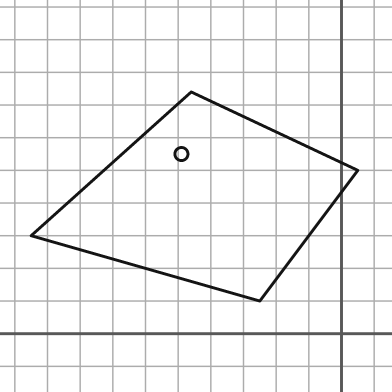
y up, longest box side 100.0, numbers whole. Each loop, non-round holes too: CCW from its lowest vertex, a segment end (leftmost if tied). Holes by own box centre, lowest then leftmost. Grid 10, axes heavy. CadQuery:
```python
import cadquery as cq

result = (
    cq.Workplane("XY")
    .moveTo(-25.0, 10.0)
    .lineTo(5.0, 50.0)
    .lineTo(-46.0, 74.0)
    .lineTo(-95.0, 30.0)
    .close()
    .moveTo(-49.0, 55.0)
    .circle(2.0)
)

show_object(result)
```